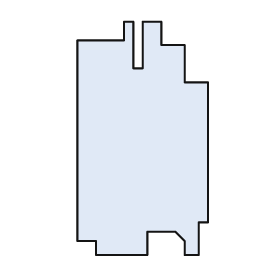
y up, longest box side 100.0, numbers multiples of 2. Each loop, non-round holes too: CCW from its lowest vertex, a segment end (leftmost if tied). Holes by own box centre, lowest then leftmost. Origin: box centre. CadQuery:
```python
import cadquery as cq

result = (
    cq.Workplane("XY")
    .moveTo(-20.0, -50.0)
    .lineTo(2.0, -50.0)
    .lineTo(2.0, -40.0)
    .lineTo(14.0, -40.0)
    .lineTo(18.0, -44.0)
    .lineTo(18.0, -50.0)
    .lineTo(24.0, -50.0)
    .lineTo(24.0, -36.0)
    .lineTo(28.0, -36.0)
    .lineTo(28.0, 24.0)
    .lineTo(18.0, 24.0)
    .lineTo(18.0, 40.0)
    .lineTo(8.0, 40.0)
    .lineTo(8.0, 50.0)
    .lineTo(0.0, 50.0)
    .lineTo(0.0, 30.0)
    .lineTo(-4.0, 30.0)
    .lineTo(-4.0, 50.0)
    .lineTo(-8.0, 50.0)
    .lineTo(-8.0, 42.0)
    .lineTo(-28.0, 42.0)
    .lineTo(-28.0, -44.0)
    .lineTo(-20.0, -44.0)
    .close()
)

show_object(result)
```